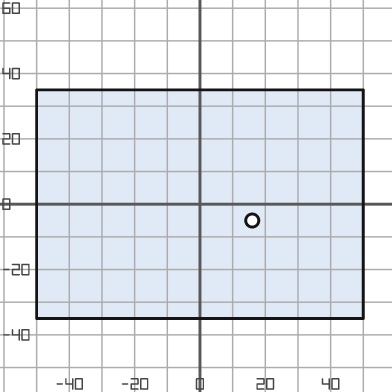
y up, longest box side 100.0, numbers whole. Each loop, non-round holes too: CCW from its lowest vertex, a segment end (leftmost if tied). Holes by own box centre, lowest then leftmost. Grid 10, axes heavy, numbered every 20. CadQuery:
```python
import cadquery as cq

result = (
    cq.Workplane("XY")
    .moveTo(-50.0, -35.0)
    .lineTo(50.0, -35.0)
    .lineTo(50.0, 35.0)
    .lineTo(-50.0, 35.0)
    .close()
    .moveTo(16.0, -5.0)
    .circle(2.0)
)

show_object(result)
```